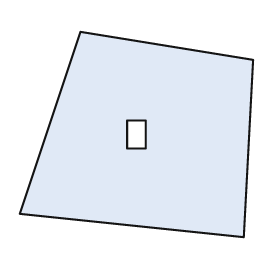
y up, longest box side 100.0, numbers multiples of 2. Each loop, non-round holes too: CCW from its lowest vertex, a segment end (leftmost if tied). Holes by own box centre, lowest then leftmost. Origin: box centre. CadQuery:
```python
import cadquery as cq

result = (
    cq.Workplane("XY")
    .moveTo(46.0, -44.0)
    .lineTo(50.0, 32.0)
    .lineTo(-24.0, 44.0)
    .lineTo(-50.0, -34.0)
    .close()
    .moveTo(-4.0, -6.0)
    .lineTo(4.0, -6.0)
    .lineTo(4.0, 6.0)
    .lineTo(-4.0, 6.0)
    .close()
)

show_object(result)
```